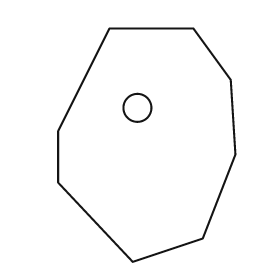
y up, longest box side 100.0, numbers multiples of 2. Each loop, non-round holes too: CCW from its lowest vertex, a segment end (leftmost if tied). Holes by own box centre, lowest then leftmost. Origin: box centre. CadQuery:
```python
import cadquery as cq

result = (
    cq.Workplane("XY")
    .moveTo(-6.0, -50.0)
    .lineTo(24.0, -40.0)
    .lineTo(38.0, -4.0)
    .lineTo(36.0, 28.0)
    .lineTo(20.0, 50.0)
    .lineTo(-16.0, 50.0)
    .lineTo(-38.0, 6.0)
    .lineTo(-38.0, -16.0)
    .close()
    .moveTo(-4.0, 16.0)
    .circle(6.0)
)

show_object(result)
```